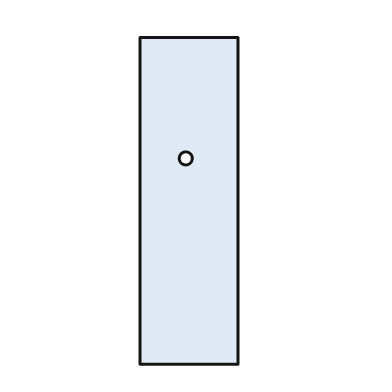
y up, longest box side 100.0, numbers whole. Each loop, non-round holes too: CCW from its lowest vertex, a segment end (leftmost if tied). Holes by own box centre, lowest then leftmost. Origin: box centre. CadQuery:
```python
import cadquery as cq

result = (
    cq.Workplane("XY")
    .moveTo(-15.0, -50.0)
    .lineTo(15.0, -50.0)
    .lineTo(15.0, 50.0)
    .lineTo(-15.0, 50.0)
    .close()
    .moveTo(-1.0, 13.0)
    .circle(2.0)
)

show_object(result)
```